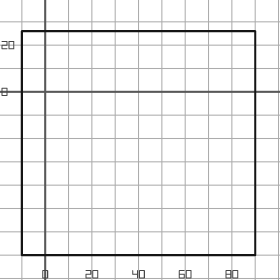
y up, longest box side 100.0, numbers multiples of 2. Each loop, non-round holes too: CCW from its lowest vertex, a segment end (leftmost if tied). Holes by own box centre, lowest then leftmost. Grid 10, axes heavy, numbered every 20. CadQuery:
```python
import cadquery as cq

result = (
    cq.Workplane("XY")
    .moveTo(-10.0, -70.0)
    .lineTo(90.0, -70.0)
    .lineTo(90.0, 26.0)
    .lineTo(-10.0, 26.0)
    .close()
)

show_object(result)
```